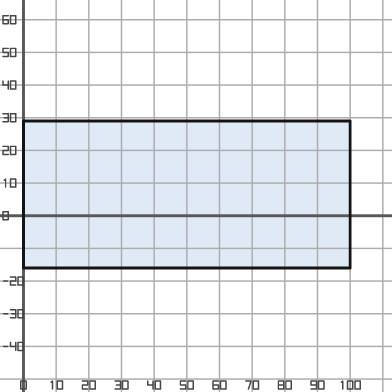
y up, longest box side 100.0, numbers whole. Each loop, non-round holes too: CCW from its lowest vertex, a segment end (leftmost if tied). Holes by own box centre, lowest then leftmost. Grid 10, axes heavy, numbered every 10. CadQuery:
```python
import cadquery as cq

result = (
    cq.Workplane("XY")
    .moveTo(0.0, -16.0)
    .lineTo(100.0, -16.0)
    .lineTo(100.0, 29.0)
    .lineTo(0.0, 29.0)
    .close()
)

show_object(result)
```